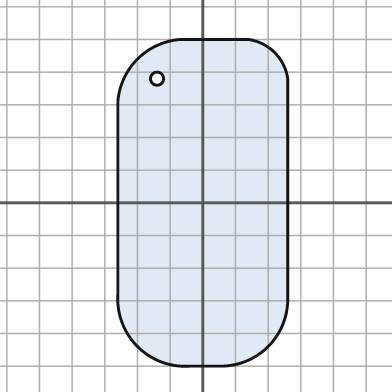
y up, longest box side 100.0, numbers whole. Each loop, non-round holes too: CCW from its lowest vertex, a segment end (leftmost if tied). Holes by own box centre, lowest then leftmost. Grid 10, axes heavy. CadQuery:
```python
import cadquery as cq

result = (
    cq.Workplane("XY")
    .moveTo(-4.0, -50.0)
    .lineTo(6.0, -50.0)
    .threePointArc((20.0, -44.0), (26.0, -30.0))
    .lineTo(26.0, 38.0)
    .threePointArc((22.0, 46.0), (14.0, 50.0))
    .lineTo(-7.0, 50.0)
    .threePointArc((-20.0, 44.0), (-26.0, 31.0))
    .lineTo(-26.0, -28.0)
    .threePointArc((-20.0, -44.0), (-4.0, -50.0))
    .close()
    .moveTo(-14.0, 38.0)
    .circle(2.0)
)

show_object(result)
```